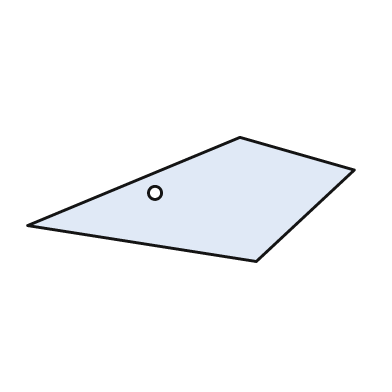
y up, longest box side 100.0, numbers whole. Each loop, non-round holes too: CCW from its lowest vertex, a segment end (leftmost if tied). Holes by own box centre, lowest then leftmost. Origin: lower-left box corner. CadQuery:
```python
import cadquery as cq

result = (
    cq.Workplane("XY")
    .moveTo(70.0, 0.0)
    .lineTo(100.0, 28.0)
    .lineTo(65.0, 38.0)
    .lineTo(0.0, 11.0)
    .close()
    .moveTo(39.0, 21.0)
    .circle(2.0)
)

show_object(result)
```